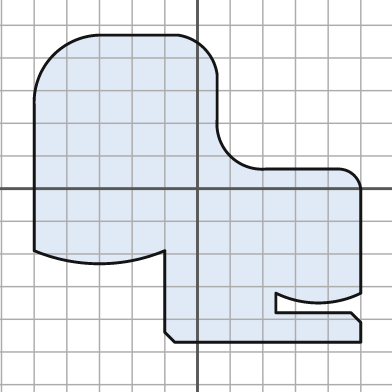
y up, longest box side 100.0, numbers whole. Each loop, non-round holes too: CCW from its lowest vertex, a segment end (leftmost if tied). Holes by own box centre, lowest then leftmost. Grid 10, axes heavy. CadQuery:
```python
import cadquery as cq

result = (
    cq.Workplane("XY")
    .moveTo(-7.0, -47.0)
    .lineTo(50.0, -47.0)
    .lineTo(50.0, -41.0)
    .lineTo(47.0, -38.0)
    .lineTo(24.0, -38.0)
    .lineTo(24.0, -32.0)
    .threePointArc((37.0, -35.0), (50.0, -32.0))
    .lineTo(50.0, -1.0)
    .threePointArc((48.0, 4.0), (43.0, 6.0))
    .lineTo(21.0, 6.0)
    .threePointArc((10.0, 10.0), (6.0, 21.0))
    .lineTo(6.0, 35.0)
    .threePointArc((2.0, 43.0), (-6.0, 47.0))
    .lineTo(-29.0, 47.0)
    .threePointArc((-44.0, 41.0), (-50.0, 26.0))
    .lineTo(-50.0, -19.0)
    .threePointArc((-30.0, -23.0), (-10.0, -19.0))
    .lineTo(-10.0, -44.0)
    .close()
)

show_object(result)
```